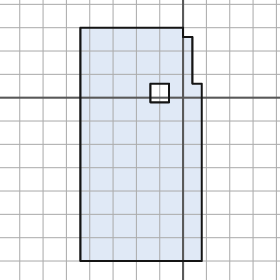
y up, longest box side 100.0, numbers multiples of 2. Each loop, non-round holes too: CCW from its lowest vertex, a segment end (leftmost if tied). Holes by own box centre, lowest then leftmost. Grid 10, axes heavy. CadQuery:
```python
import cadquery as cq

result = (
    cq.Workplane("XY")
    .moveTo(-44.0, -70.0)
    .lineTo(8.0, -70.0)
    .lineTo(8.0, 6.0)
    .lineTo(4.0, 6.0)
    .lineTo(4.0, 26.0)
    .lineTo(0.0, 26.0)
    .lineTo(0.0, 30.0)
    .lineTo(-44.0, 30.0)
    .close()
    .moveTo(-14.0, -2.0)
    .lineTo(-6.0, -2.0)
    .lineTo(-6.0, 6.0)
    .lineTo(-14.0, 6.0)
    .close()
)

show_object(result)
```